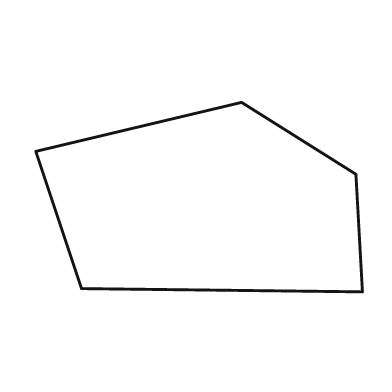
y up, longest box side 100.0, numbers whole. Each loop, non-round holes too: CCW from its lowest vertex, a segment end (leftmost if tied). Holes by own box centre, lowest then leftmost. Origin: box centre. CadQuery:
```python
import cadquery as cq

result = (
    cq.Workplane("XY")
    .moveTo(50.0, -29.0)
    .lineTo(48.0, 7.0)
    .lineTo(13.0, 29.0)
    .lineTo(-50.0, 14.0)
    .lineTo(-36.0, -28.0)
    .close()
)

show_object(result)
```